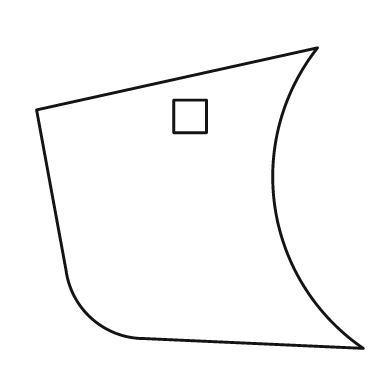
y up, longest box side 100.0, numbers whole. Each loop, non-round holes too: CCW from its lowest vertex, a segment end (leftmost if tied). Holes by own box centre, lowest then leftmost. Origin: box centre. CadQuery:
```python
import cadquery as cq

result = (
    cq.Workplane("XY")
    .moveTo(50.0, -46.0)
    .threePointArc((23.0, -3.0), (36.0, 46.0))
    .lineTo(-50.0, 27.0)
    .lineTo(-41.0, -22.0)
    .threePointArc((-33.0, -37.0), (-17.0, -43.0))
    .close()
    .moveTo(-8.0, 20.0)
    .lineTo(2.0, 20.0)
    .lineTo(2.0, 30.0)
    .lineTo(-8.0, 30.0)
    .close()
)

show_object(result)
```